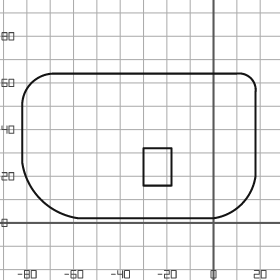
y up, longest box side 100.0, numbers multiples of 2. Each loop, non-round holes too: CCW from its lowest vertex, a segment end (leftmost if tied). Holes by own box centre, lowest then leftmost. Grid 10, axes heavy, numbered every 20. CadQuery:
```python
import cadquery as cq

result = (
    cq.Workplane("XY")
    .moveTo(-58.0, 2.0)
    .lineTo(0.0, 2.0)
    .threePointArc((12.0, 8.0), (18.0, 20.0))
    .lineTo(18.0, 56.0)
    .threePointArc((16.0, 62.0), (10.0, 64.0))
    .lineTo(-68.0, 64.0)
    .threePointArc((-78.0, 60.0), (-82.0, 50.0))
    .lineTo(-82.0, 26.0)
    .threePointArc((-74.0, 10.0), (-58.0, 2.0))
    .close()
    .moveTo(-30.0, 16.0)
    .lineTo(-18.0, 16.0)
    .lineTo(-18.0, 32.0)
    .lineTo(-30.0, 32.0)
    .close()
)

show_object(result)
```